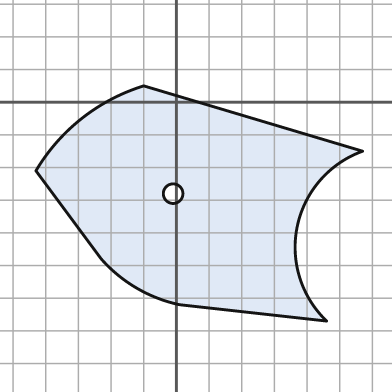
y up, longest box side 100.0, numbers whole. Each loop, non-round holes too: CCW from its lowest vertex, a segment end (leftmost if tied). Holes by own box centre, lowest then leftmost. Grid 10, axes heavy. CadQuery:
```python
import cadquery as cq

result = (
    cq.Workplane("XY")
    .moveTo(46.0, -67.0)
    .threePointArc((37.0, -38.0), (57.0, -15.0))
    .lineTo(-10.0, 5.0)
    .threePointArc((-29.0, -5.0), (-43.0, -21.0))
    .lineTo(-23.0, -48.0)
    .threePointArc((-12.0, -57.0), (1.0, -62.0))
    .close()
    .moveTo(-1.0, -28.0)
    .circle(3.0)
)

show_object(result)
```